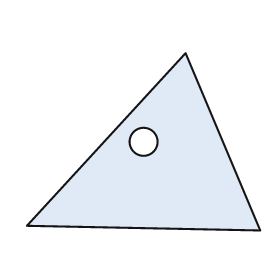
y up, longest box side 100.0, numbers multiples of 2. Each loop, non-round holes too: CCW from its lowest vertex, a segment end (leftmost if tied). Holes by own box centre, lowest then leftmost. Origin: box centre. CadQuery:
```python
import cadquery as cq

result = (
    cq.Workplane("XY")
    .moveTo(50.0, -38.0)
    .lineTo(18.0, 38.0)
    .lineTo(-50.0, -36.0)
    .close()
    .moveTo(0.0, 0.0)
    .circle(6.0)
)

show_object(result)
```